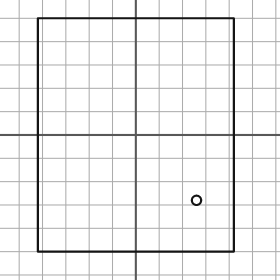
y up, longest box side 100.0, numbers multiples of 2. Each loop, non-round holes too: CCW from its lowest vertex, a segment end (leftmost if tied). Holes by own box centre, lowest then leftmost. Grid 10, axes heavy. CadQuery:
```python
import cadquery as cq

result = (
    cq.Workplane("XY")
    .moveTo(-42.0, -50.0)
    .lineTo(42.0, -50.0)
    .lineTo(42.0, 50.0)
    .lineTo(-42.0, 50.0)
    .close()
    .moveTo(26.0, -28.0)
    .circle(2.0)
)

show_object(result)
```